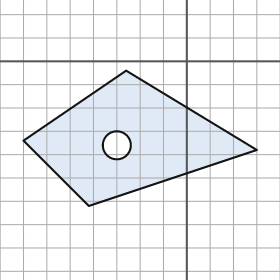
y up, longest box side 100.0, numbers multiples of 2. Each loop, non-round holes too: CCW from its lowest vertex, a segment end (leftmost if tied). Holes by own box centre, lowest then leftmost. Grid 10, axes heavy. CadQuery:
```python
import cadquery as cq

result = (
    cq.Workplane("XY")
    .moveTo(-42.0, -62.0)
    .lineTo(30.0, -38.0)
    .lineTo(-26.0, -4.0)
    .lineTo(-70.0, -34.0)
    .close()
    .moveTo(-30.0, -36.0)
    .circle(6.0)
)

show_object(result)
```